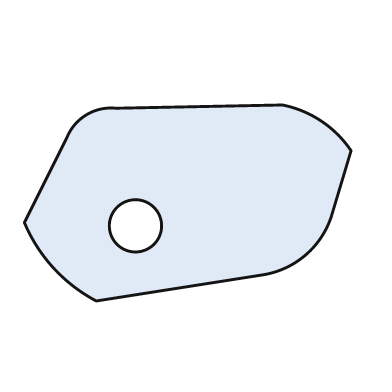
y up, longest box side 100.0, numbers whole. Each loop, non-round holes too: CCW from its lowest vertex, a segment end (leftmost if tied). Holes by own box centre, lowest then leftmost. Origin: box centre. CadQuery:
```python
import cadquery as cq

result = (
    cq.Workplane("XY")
    .moveTo(-28.0, -30.0)
    .lineTo(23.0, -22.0)
    .threePointArc((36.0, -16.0), (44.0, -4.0))
    .lineTo(50.0, 16.0)
    .threePointArc((41.0, 25.0), (29.0, 30.0))
    .lineTo(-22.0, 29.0)
    .threePointArc((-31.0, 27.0), (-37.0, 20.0))
    .lineTo(-50.0, -6.0)
    .threePointArc((-41.0, -20.0), (-28.0, -30.0))
    .close()
    .moveTo(-16.0, -7.0)
    .circle(8.0)
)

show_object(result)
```